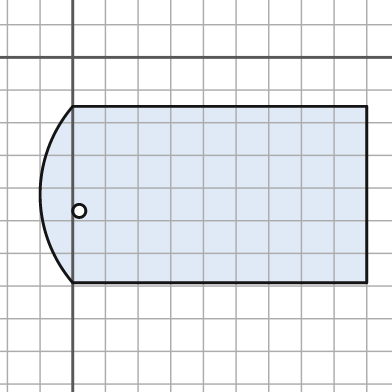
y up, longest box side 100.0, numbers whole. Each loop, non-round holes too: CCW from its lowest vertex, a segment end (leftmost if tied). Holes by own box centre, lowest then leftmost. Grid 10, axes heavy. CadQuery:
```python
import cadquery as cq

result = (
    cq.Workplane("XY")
    .moveTo(0.0, -69.0)
    .lineTo(90.0, -69.0)
    .lineTo(90.0, -15.0)
    .lineTo(0.0, -15.0)
    .threePointArc((-10.0, -42.0), (0.0, -69.0))
    .close()
    .moveTo(2.0, -47.0)
    .circle(2.0)
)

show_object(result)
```